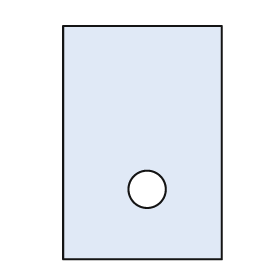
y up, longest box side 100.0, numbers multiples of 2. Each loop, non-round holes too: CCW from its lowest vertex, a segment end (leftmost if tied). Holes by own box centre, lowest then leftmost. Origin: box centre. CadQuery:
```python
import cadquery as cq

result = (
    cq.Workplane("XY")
    .moveTo(-34.0, -50.0)
    .lineTo(34.0, -50.0)
    .lineTo(34.0, 50.0)
    .lineTo(-34.0, 50.0)
    .close()
    .moveTo(2.0, -20.0)
    .circle(8.0)
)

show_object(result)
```